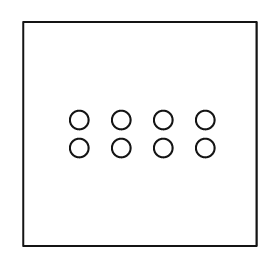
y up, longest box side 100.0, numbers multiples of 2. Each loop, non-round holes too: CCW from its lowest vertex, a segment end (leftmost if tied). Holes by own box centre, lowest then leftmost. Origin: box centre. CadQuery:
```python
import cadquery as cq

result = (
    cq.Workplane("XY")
    .moveTo(-50.0, -48.0)
    .lineTo(50.0, -48.0)
    .lineTo(50.0, 48.0)
    .lineTo(-50.0, 48.0)
    .close()
    .moveTo(-26.0, -6.0)
    .circle(4.0)
    .moveTo(-8.0, -6.0)
    .circle(4.0)
    .moveTo(10.0, -6.0)
    .circle(4.0)
    .moveTo(28.0, -6.0)
    .circle(4.0)
    .moveTo(-26.0, 6.0)
    .circle(4.0)
    .moveTo(-8.0, 6.0)
    .circle(4.0)
    .moveTo(10.0, 6.0)
    .circle(4.0)
    .moveTo(28.0, 6.0)
    .circle(4.0)
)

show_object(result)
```